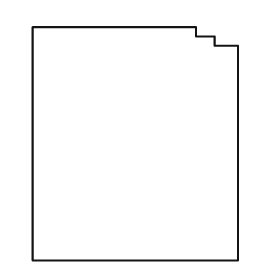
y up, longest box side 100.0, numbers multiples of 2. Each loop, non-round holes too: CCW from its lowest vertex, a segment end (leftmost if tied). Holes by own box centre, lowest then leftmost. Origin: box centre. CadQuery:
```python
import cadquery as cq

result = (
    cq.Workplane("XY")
    .moveTo(-44.0, -50.0)
    .lineTo(44.0, -50.0)
    .lineTo(44.0, 42.0)
    .lineTo(34.0, 42.0)
    .lineTo(34.0, 46.0)
    .lineTo(26.0, 46.0)
    .lineTo(26.0, 50.0)
    .lineTo(-44.0, 50.0)
    .close()
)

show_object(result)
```